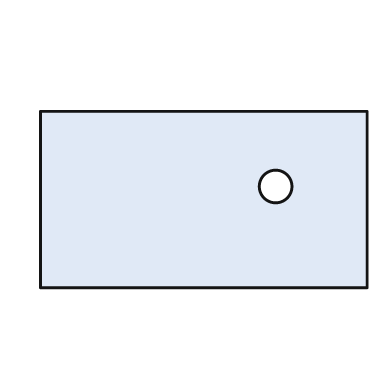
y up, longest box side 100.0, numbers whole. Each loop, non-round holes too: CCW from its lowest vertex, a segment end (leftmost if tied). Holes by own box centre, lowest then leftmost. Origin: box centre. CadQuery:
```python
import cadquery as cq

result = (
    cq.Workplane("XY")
    .moveTo(-50.0, -27.0)
    .lineTo(50.0, -27.0)
    .lineTo(50.0, 27.0)
    .lineTo(-50.0, 27.0)
    .close()
    .moveTo(22.0, 4.0)
    .circle(5.0)
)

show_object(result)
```